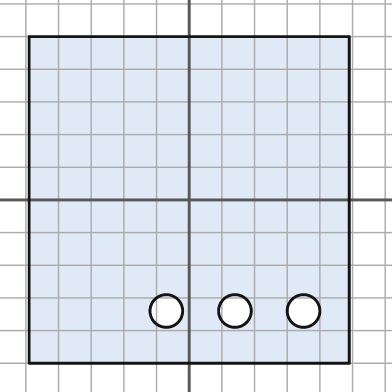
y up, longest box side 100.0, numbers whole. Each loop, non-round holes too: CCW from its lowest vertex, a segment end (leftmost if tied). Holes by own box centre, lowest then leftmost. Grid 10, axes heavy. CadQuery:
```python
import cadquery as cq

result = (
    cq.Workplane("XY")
    .moveTo(-49.0, -50.0)
    .lineTo(49.0, -50.0)
    .lineTo(49.0, 50.0)
    .lineTo(-49.0, 50.0)
    .close()
    .moveTo(-7.0, -34.0)
    .circle(5.0)
    .moveTo(14.0, -34.0)
    .circle(5.0)
    .moveTo(35.0, -34.0)
    .circle(5.0)
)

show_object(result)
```